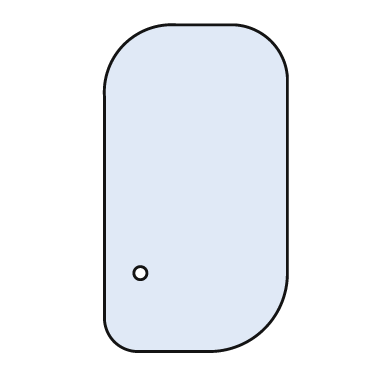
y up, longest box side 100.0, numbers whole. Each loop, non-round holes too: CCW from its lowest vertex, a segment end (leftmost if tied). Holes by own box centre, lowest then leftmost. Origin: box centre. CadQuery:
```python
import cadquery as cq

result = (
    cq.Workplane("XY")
    .moveTo(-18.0, -50.0)
    .lineTo(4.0, -50.0)
    .threePointArc((21.0, -43.0), (28.0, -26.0))
    .lineTo(28.0, 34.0)
    .threePointArc((23.0, 45.0), (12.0, 50.0))
    .lineTo(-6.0, 50.0)
    .threePointArc((-22.0, 44.0), (-28.0, 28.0))
    .lineTo(-28.0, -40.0)
    .threePointArc((-25.0, -47.0), (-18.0, -50.0))
    .close()
    .moveTo(-17.0, -26.0)
    .circle(2.0)
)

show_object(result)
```